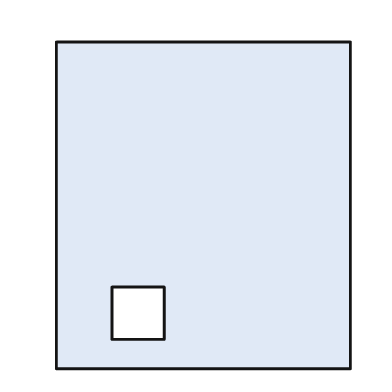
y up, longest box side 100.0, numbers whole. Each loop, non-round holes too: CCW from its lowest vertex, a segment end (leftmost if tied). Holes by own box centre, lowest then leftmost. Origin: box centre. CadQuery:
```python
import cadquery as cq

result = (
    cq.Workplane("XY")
    .moveTo(-45.0, -50.0)
    .lineTo(45.0, -50.0)
    .lineTo(45.0, 50.0)
    .lineTo(-45.0, 50.0)
    .close()
    .moveTo(-28.0, -41.0)
    .lineTo(-12.0, -41.0)
    .lineTo(-12.0, -25.0)
    .lineTo(-28.0, -25.0)
    .close()
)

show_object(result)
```